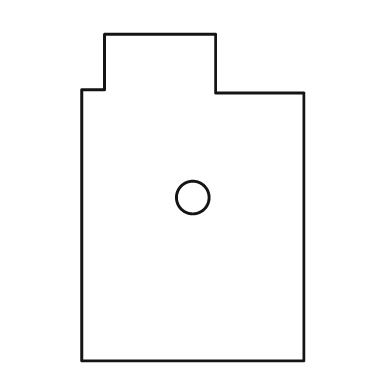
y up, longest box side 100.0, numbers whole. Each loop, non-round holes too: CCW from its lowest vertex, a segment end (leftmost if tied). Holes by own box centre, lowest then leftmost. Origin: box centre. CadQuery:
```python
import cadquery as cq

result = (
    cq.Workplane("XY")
    .moveTo(-34.0, -50.0)
    .lineTo(34.0, -50.0)
    .lineTo(34.0, 32.0)
    .lineTo(7.0, 32.0)
    .lineTo(7.0, 50.0)
    .lineTo(-27.0, 50.0)
    .lineTo(-27.0, 33.0)
    .lineTo(-34.0, 33.0)
    .close()
    .moveTo(0.0, 0.0)
    .circle(5.0)
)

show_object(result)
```